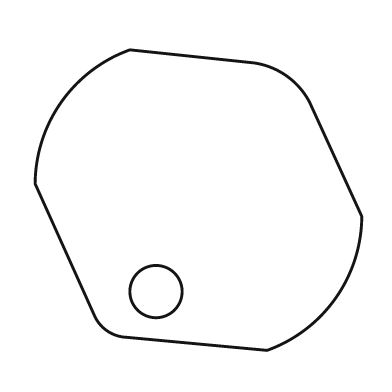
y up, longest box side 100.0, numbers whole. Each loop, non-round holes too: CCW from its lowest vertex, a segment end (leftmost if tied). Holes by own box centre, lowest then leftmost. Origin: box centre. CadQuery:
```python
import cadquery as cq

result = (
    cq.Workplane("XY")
    .moveTo(21.0, -46.0)
    .threePointArc((42.0, -30.0), (50.0, -5.0))
    .lineTo(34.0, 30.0)
    .threePointArc((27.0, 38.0), (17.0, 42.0))
    .lineTo(-21.0, 46.0)
    .threePointArc((-42.0, 30.0), (-50.0, 5.0))
    .lineTo(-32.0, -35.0)
    .threePointArc((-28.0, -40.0), (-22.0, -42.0))
    .close()
    .moveTo(-13.0, -28.0)
    .circle(8.0)
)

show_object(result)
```